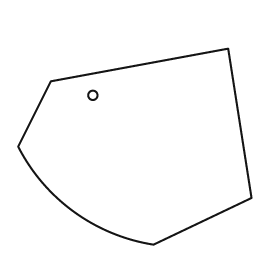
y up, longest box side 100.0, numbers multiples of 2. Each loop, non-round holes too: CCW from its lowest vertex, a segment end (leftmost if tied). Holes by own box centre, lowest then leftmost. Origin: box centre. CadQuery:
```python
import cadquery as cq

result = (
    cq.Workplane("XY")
    .moveTo(8.0, -42.0)
    .lineTo(50.0, -22.0)
    .lineTo(40.0, 42.0)
    .lineTo(-36.0, 28.0)
    .lineTo(-50.0, 0.0)
    .threePointArc((-26.0, -28.0), (8.0, -42.0))
    .close()
    .moveTo(-18.0, 22.0)
    .circle(2.0)
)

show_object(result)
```